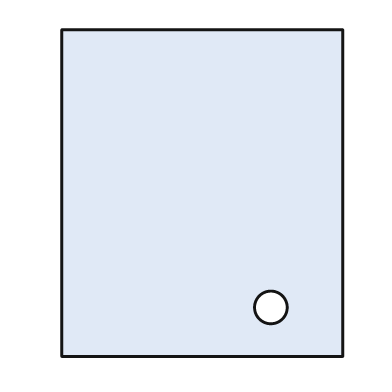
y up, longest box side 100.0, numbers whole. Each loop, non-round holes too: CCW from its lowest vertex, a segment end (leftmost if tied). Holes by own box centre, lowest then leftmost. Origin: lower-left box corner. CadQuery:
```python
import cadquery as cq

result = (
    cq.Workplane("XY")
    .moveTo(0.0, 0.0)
    .lineTo(86.0, 0.0)
    .lineTo(86.0, 100.0)
    .lineTo(0.0, 100.0)
    .close()
    .moveTo(64.0, 15.0)
    .circle(5.0)
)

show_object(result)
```